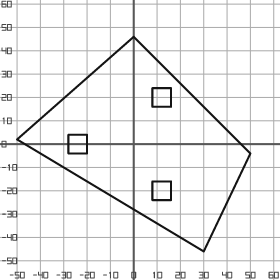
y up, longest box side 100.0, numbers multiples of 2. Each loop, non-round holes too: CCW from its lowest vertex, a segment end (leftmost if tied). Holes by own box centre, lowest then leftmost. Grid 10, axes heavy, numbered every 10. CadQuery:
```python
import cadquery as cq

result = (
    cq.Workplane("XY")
    .moveTo(30.0, -46.0)
    .lineTo(50.0, -4.0)
    .lineTo(0.0, 46.0)
    .lineTo(-50.0, 2.0)
    .close()
    .moveTo(8.0, -24.0)
    .lineTo(16.0, -24.0)
    .lineTo(16.0, -16.0)
    .lineTo(8.0, -16.0)
    .close()
    .moveTo(-28.0, -4.0)
    .lineTo(-20.0, -4.0)
    .lineTo(-20.0, 4.0)
    .lineTo(-28.0, 4.0)
    .close()
    .moveTo(8.0, 16.0)
    .lineTo(16.0, 16.0)
    .lineTo(16.0, 24.0)
    .lineTo(8.0, 24.0)
    .close()
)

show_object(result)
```